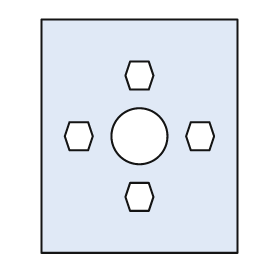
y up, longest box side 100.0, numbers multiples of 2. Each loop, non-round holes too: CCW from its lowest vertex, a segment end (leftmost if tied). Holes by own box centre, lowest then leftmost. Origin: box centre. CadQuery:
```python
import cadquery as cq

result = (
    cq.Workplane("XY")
    .moveTo(-42.0, -50.0)
    .lineTo(42.0, -50.0)
    .lineTo(42.0, 50.0)
    .lineTo(-42.0, 50.0)
    .close()
    .moveTo(-4.0, -32.0)
    .lineTo(4.0, -32.0)
    .lineTo(6.0, -26.0)
    .lineTo(4.0, -20.0)
    .lineTo(-4.0, -20.0)
    .lineTo(-6.0, -26.0)
    .close()
    .moveTo(-30.0, -6.0)
    .lineTo(-22.0, -6.0)
    .lineTo(-20.0, 0.0)
    .lineTo(-22.0, 6.0)
    .lineTo(-30.0, 6.0)
    .lineTo(-32.0, 0.0)
    .close()
    .moveTo(0.0, 0.0)
    .circle(12.0)
    .moveTo(22.0, -6.0)
    .lineTo(30.0, -6.0)
    .lineTo(32.0, 0.0)
    .lineTo(30.0, 6.0)
    .lineTo(22.0, 6.0)
    .lineTo(20.0, 0.0)
    .close()
    .moveTo(-4.0, 20.0)
    .lineTo(4.0, 20.0)
    .lineTo(6.0, 26.0)
    .lineTo(4.0, 32.0)
    .lineTo(-4.0, 32.0)
    .lineTo(-6.0, 26.0)
    .close()
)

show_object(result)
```